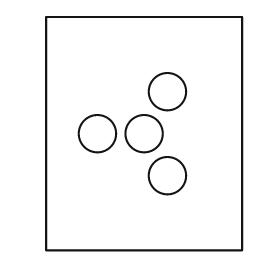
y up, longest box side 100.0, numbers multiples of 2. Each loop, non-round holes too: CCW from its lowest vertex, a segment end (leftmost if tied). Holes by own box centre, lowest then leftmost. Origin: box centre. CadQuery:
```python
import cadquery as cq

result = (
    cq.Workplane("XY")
    .moveTo(-42.0, -50.0)
    .lineTo(42.0, -50.0)
    .lineTo(42.0, 50.0)
    .lineTo(-42.0, 50.0)
    .close()
    .moveTo(10.0, -18.0)
    .circle(8.0)
    .moveTo(-20.0, 0.0)
    .circle(8.0)
    .moveTo(0.0, 0.0)
    .circle(8.0)
    .moveTo(10.0, 18.0)
    .circle(8.0)
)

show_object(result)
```